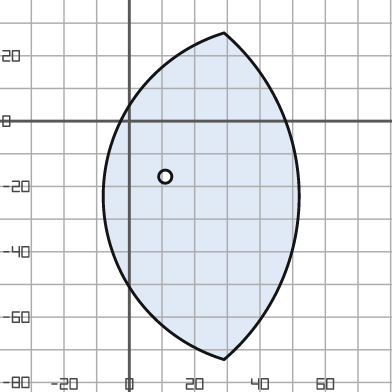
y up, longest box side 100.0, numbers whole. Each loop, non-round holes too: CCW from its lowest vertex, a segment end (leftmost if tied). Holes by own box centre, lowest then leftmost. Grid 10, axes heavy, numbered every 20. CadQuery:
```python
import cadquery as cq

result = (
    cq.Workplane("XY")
    .moveTo(29.0, -73.0)
    .threePointArc((52.0, -23.0), (29.0, 27.0))
    .threePointArc((-8.0, -23.0), (29.0, -73.0))
    .close()
    .moveTo(11.0, -17.0)
    .circle(2.0)
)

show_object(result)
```